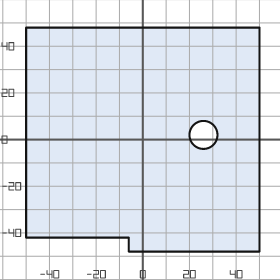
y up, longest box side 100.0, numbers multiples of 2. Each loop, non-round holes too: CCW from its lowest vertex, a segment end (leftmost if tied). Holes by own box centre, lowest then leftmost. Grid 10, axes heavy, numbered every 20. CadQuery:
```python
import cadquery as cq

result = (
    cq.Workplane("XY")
    .moveTo(-6.0, -48.0)
    .lineTo(50.0, -48.0)
    .lineTo(50.0, 48.0)
    .lineTo(-50.0, 48.0)
    .lineTo(-50.0, -42.0)
    .lineTo(-6.0, -42.0)
    .close()
    .moveTo(26.0, 2.0)
    .circle(6.0)
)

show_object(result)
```